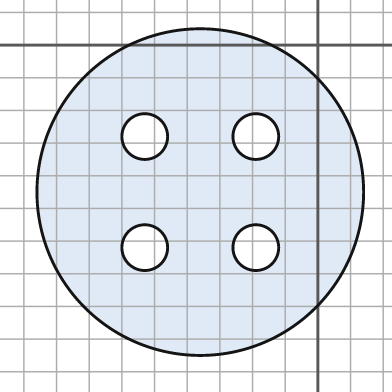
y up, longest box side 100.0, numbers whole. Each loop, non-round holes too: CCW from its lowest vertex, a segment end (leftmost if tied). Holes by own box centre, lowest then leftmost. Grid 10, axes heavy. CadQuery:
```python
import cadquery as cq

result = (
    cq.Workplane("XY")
    .moveTo(-36.0, -45.0)
    .circle(50.0)
    .moveTo(-53.0, -62.0)
    .circle(7.0)
    .moveTo(-19.0, -62.0)
    .circle(7.0)
    .moveTo(-53.0, -28.0)
    .circle(7.0)
    .moveTo(-19.0, -28.0)
    .circle(7.0)
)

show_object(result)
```